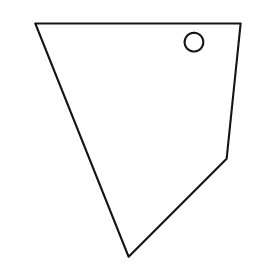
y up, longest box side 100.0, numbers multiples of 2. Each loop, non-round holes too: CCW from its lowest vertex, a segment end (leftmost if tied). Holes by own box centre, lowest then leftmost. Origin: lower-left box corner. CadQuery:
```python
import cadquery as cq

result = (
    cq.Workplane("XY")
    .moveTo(40.0, 0.0)
    .lineTo(82.0, 42.0)
    .lineTo(88.0, 100.0)
    .lineTo(0.0, 100.0)
    .close()
    .moveTo(68.0, 92.0)
    .circle(4.0)
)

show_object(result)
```